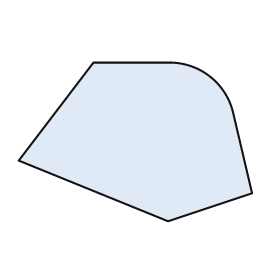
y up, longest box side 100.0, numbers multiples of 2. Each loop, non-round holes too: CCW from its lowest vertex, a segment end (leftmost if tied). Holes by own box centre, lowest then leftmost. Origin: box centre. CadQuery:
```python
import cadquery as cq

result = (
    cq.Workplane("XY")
    .moveTo(14.0, -34.0)
    .lineTo(50.0, -22.0)
    .lineTo(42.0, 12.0)
    .threePointArc((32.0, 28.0), (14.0, 34.0))
    .lineTo(-18.0, 34.0)
    .lineTo(-50.0, -8.0)
    .close()
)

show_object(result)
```